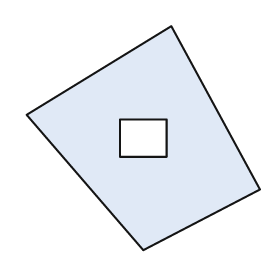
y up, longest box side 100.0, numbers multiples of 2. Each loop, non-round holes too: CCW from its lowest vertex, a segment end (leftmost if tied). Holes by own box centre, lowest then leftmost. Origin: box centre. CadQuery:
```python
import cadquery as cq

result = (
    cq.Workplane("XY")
    .moveTo(0.0, -48.0)
    .lineTo(50.0, -22.0)
    .lineTo(12.0, 48.0)
    .lineTo(-50.0, 10.0)
    .close()
    .moveTo(-10.0, -8.0)
    .lineTo(10.0, -8.0)
    .lineTo(10.0, 8.0)
    .lineTo(-10.0, 8.0)
    .close()
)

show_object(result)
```